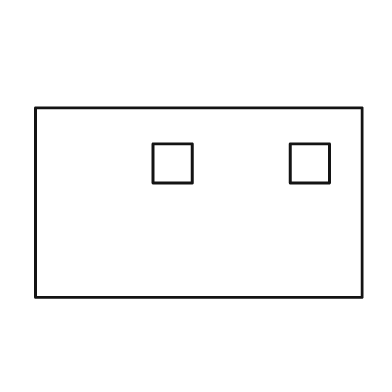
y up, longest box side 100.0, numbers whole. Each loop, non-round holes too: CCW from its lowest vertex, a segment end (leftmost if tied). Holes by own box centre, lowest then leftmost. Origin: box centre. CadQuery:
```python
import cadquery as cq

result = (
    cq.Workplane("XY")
    .moveTo(-50.0, -29.0)
    .lineTo(50.0, -29.0)
    .lineTo(50.0, 29.0)
    .lineTo(-50.0, 29.0)
    .close()
    .moveTo(-14.0, 6.0)
    .lineTo(-2.0, 6.0)
    .lineTo(-2.0, 18.0)
    .lineTo(-14.0, 18.0)
    .close()
    .moveTo(28.0, 6.0)
    .lineTo(40.0, 6.0)
    .lineTo(40.0, 18.0)
    .lineTo(28.0, 18.0)
    .close()
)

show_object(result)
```